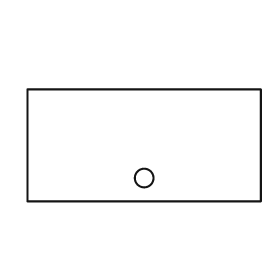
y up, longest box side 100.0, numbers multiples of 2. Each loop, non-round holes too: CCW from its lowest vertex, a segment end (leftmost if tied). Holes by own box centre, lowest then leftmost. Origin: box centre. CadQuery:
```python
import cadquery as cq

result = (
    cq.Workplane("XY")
    .moveTo(-50.0, -24.0)
    .lineTo(50.0, -24.0)
    .lineTo(50.0, 24.0)
    .lineTo(-50.0, 24.0)
    .close()
    .moveTo(0.0, -14.0)
    .circle(4.0)
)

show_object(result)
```